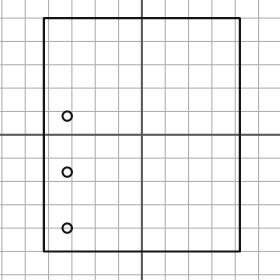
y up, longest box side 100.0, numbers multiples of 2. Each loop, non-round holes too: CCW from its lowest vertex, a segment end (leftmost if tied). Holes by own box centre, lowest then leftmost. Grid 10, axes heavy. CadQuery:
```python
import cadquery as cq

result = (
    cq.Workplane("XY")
    .moveTo(-42.0, -50.0)
    .lineTo(42.0, -50.0)
    .lineTo(42.0, 50.0)
    .lineTo(-42.0, 50.0)
    .close()
    .moveTo(-32.0, -40.0)
    .circle(2.0)
    .moveTo(-32.0, -16.0)
    .circle(2.0)
    .moveTo(-32.0, 8.0)
    .circle(2.0)
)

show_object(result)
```